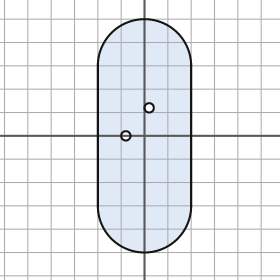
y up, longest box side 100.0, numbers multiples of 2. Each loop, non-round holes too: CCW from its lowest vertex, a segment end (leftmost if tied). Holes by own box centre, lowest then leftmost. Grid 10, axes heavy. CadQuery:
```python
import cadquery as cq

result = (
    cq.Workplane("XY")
    .moveTo(-20.0, -30.0)
    .threePointArc((0.0, -50.0), (20.0, -30.0))
    .lineTo(20.0, 30.0)
    .threePointArc((0.0, 50.0), (-20.0, 30.0))
    .close()
    .moveTo(-8.0, 0.0)
    .circle(2.0)
    .moveTo(2.0, 12.0)
    .circle(2.0)
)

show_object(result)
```